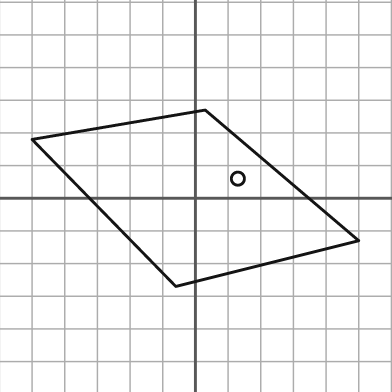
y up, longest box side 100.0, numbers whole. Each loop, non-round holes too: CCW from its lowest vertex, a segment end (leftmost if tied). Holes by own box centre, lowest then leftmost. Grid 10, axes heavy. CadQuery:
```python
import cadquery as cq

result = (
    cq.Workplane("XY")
    .moveTo(-6.0, -27.0)
    .lineTo(50.0, -13.0)
    .lineTo(3.0, 27.0)
    .lineTo(-50.0, 18.0)
    .close()
    .moveTo(13.0, 6.0)
    .circle(2.0)
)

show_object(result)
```